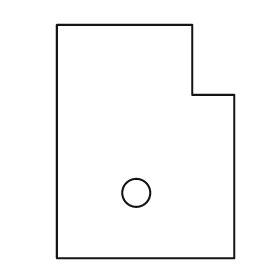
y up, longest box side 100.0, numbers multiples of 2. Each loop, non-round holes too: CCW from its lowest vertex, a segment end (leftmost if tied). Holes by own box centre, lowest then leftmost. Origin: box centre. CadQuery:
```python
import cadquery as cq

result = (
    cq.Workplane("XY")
    .moveTo(-38.0, -50.0)
    .lineTo(38.0, -50.0)
    .lineTo(38.0, 20.0)
    .lineTo(20.0, 20.0)
    .lineTo(20.0, 50.0)
    .lineTo(-38.0, 50.0)
    .close()
    .moveTo(-4.0, -22.0)
    .circle(6.0)
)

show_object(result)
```